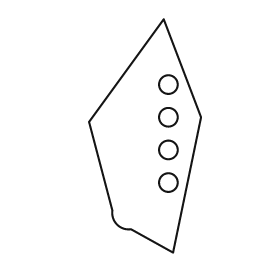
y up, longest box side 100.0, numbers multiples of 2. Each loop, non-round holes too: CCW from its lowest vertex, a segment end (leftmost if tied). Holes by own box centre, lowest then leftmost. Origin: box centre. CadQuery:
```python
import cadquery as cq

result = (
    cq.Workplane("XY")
    .moveTo(12.0, -50.0)
    .lineTo(24.0, 8.0)
    .lineTo(8.0, 50.0)
    .lineTo(-24.0, 6.0)
    .lineTo(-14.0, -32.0)
    .threePointArc((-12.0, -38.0), (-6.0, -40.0))
    .close()
    .moveTo(10.0, -20.0)
    .circle(4.0)
    .moveTo(10.0, -6.0)
    .circle(4.0)
    .moveTo(10.0, 8.0)
    .circle(4.0)
    .moveTo(10.0, 22.0)
    .circle(4.0)
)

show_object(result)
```